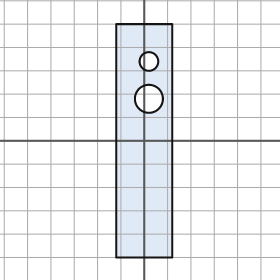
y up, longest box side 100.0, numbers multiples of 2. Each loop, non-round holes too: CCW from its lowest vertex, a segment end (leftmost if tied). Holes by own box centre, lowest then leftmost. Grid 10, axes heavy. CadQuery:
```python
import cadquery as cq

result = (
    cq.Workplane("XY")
    .moveTo(-12.0, -50.0)
    .lineTo(12.0, -50.0)
    .lineTo(12.0, 50.0)
    .lineTo(-12.0, 50.0)
    .close()
    .moveTo(2.0, 18.0)
    .circle(6.0)
    .moveTo(2.0, 34.0)
    .circle(4.0)
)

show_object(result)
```